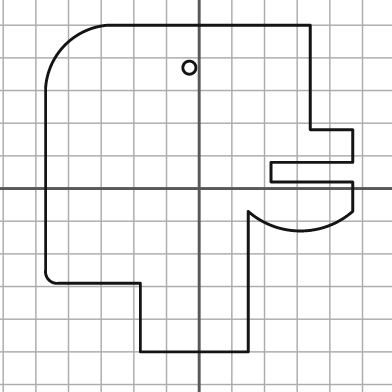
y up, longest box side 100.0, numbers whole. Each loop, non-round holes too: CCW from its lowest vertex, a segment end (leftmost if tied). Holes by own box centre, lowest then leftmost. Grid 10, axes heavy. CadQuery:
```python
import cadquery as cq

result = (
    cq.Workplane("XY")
    .moveTo(-18.0, -50.0)
    .lineTo(15.0, -50.0)
    .lineTo(15.0, -7.0)
    .threePointArc((31.0, -13.0), (47.0, -7.0))
    .lineTo(47.0, 2.0)
    .lineTo(22.0, 2.0)
    .lineTo(22.0, 8.0)
    .lineTo(47.0, 8.0)
    .lineTo(47.0, 18.0)
    .lineTo(34.0, 18.0)
    .lineTo(34.0, 50.0)
    .lineTo(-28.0, 50.0)
    .threePointArc((-41.0, 44.0), (-47.0, 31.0))
    .lineTo(-47.0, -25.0)
    .threePointArc((-46.0, -28.0), (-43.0, -29.0))
    .lineTo(-18.0, -29.0)
    .close()
    .moveTo(-3.0, 37.0)
    .circle(2.0)
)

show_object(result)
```